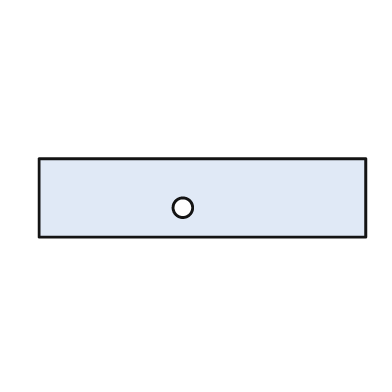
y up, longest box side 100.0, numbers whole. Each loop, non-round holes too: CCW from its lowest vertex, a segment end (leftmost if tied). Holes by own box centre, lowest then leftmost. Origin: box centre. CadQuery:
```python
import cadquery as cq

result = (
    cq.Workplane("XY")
    .moveTo(-50.0, -12.0)
    .lineTo(50.0, -12.0)
    .lineTo(50.0, 12.0)
    .lineTo(-50.0, 12.0)
    .close()
    .moveTo(-6.0, -3.0)
    .circle(3.0)
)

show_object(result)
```